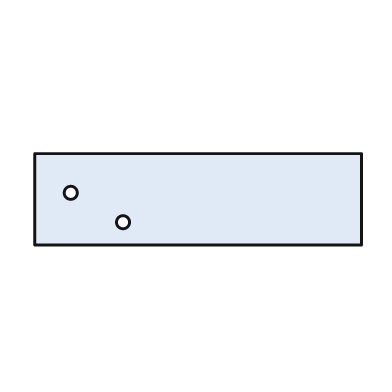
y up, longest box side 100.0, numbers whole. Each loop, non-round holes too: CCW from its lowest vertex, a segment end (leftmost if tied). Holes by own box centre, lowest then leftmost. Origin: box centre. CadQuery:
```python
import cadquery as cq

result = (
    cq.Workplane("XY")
    .moveTo(-50.0, -14.0)
    .lineTo(50.0, -14.0)
    .lineTo(50.0, 14.0)
    .lineTo(-50.0, 14.0)
    .close()
    .moveTo(-23.0, -7.0)
    .circle(2.0)
    .moveTo(-39.0, 2.0)
    .circle(2.0)
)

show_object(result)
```